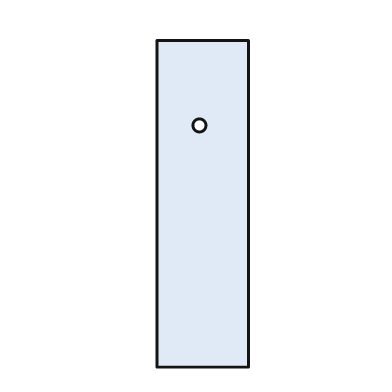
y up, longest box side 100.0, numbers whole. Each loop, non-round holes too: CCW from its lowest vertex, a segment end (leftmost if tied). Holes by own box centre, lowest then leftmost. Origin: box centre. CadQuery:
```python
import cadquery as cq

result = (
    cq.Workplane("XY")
    .moveTo(-14.0, -50.0)
    .lineTo(14.0, -50.0)
    .lineTo(14.0, 50.0)
    .lineTo(-14.0, 50.0)
    .close()
    .moveTo(-1.0, 24.0)
    .circle(2.0)
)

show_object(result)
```